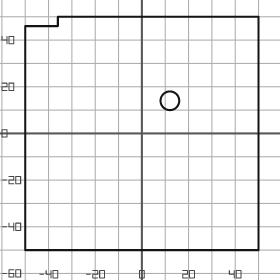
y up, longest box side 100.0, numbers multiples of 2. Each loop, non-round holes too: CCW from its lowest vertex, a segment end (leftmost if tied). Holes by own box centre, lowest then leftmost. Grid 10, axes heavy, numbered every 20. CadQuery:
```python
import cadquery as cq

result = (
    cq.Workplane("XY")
    .moveTo(-50.0, -50.0)
    .lineTo(50.0, -50.0)
    .lineTo(50.0, 50.0)
    .lineTo(-36.0, 50.0)
    .lineTo(-36.0, 46.0)
    .lineTo(-50.0, 46.0)
    .close()
    .moveTo(12.0, 14.0)
    .circle(4.0)
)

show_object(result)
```